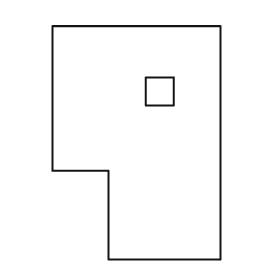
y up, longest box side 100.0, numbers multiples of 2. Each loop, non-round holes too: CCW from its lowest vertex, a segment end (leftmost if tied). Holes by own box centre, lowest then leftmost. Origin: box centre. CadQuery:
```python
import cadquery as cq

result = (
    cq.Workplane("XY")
    .moveTo(-12.0, -50.0)
    .lineTo(36.0, -50.0)
    .lineTo(36.0, 50.0)
    .lineTo(-36.0, 50.0)
    .lineTo(-36.0, -12.0)
    .lineTo(-12.0, -12.0)
    .close()
    .moveTo(4.0, 16.0)
    .lineTo(16.0, 16.0)
    .lineTo(16.0, 28.0)
    .lineTo(4.0, 28.0)
    .close()
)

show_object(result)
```